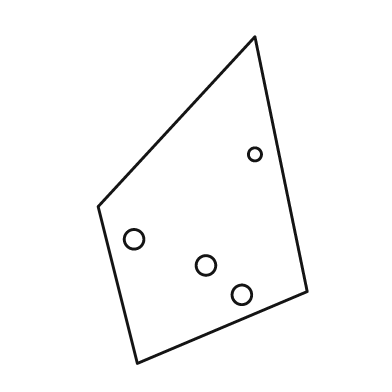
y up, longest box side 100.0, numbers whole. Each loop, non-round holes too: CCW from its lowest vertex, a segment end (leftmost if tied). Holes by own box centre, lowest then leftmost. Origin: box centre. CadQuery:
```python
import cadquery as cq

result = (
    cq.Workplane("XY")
    .moveTo(-20.0, -50.0)
    .lineTo(32.0, -28.0)
    .lineTo(16.0, 50.0)
    .lineTo(-32.0, -2.0)
    .close()
    .moveTo(12.0, -29.0)
    .circle(3.0)
    .moveTo(1.0, -20.0)
    .circle(3.0)
    .moveTo(-21.0, -12.0)
    .circle(3.0)
    .moveTo(16.0, 14.0)
    .circle(2.0)
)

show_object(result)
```